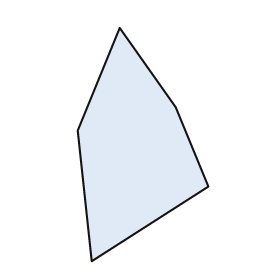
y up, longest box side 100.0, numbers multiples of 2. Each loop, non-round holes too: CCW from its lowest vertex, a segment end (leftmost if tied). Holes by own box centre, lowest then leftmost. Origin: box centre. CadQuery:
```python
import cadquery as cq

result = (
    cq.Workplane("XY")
    .moveTo(-22.0, -50.0)
    .lineTo(28.0, -18.0)
    .lineTo(14.0, 16.0)
    .lineTo(-10.0, 50.0)
    .lineTo(-28.0, 6.0)
    .close()
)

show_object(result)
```